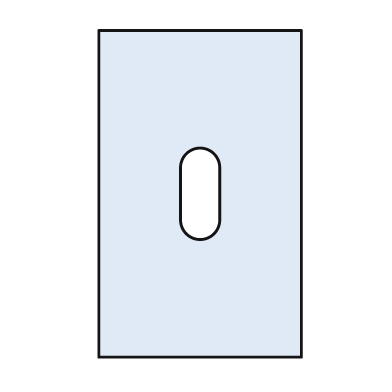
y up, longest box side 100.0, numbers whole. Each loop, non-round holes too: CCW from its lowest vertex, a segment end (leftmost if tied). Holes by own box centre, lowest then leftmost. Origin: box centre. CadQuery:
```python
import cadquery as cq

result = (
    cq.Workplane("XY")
    .moveTo(-31.0, -50.0)
    .lineTo(31.0, -50.0)
    .lineTo(31.0, 50.0)
    .lineTo(-31.0, 50.0)
    .close()
    .moveTo(-6.0, -8.0)
    .threePointArc((0.0, -14.0), (6.0, -8.0))
    .lineTo(6.0, 8.0)
    .threePointArc((0.0, 14.0), (-6.0, 8.0))
    .close()
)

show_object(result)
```